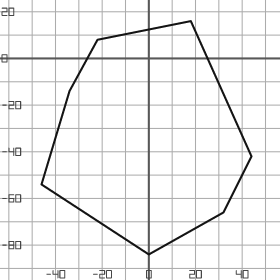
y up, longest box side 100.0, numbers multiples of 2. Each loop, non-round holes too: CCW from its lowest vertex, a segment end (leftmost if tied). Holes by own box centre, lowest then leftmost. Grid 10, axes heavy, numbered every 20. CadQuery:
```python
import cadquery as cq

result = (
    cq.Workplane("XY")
    .moveTo(0.0, -84.0)
    .lineTo(32.0, -66.0)
    .lineTo(44.0, -42.0)
    .lineTo(18.0, 16.0)
    .lineTo(-22.0, 8.0)
    .lineTo(-34.0, -14.0)
    .lineTo(-46.0, -54.0)
    .close()
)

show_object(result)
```